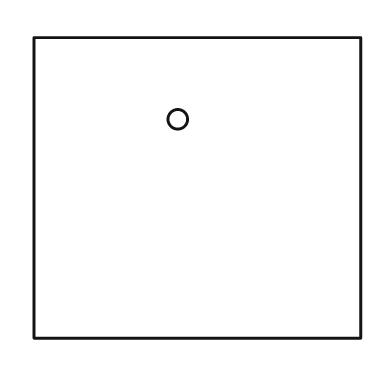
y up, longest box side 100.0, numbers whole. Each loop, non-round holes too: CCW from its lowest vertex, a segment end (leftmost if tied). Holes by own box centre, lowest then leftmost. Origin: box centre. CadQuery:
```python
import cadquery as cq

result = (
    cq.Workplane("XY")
    .moveTo(-50.0, -46.0)
    .lineTo(50.0, -46.0)
    .lineTo(50.0, 46.0)
    .lineTo(-50.0, 46.0)
    .close()
    .moveTo(-6.0, 21.0)
    .circle(3.0)
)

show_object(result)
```